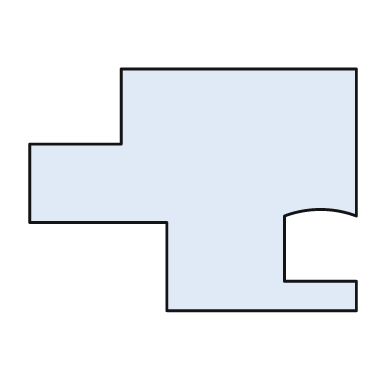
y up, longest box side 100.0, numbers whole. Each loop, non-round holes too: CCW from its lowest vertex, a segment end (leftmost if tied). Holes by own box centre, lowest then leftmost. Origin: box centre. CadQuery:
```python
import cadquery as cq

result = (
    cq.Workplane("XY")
    .moveTo(-8.0, -37.0)
    .lineTo(50.0, -37.0)
    .lineTo(50.0, -28.0)
    .lineTo(28.0, -28.0)
    .lineTo(28.0, -8.0)
    .threePointArc((39.0, -6.0), (50.0, -8.0))
    .lineTo(50.0, 37.0)
    .lineTo(-22.0, 37.0)
    .lineTo(-22.0, 14.0)
    .lineTo(-50.0, 14.0)
    .lineTo(-50.0, -10.0)
    .lineTo(-8.0, -10.0)
    .close()
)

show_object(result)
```